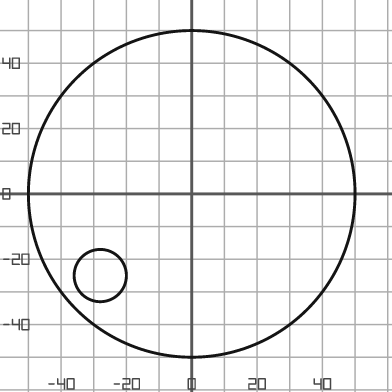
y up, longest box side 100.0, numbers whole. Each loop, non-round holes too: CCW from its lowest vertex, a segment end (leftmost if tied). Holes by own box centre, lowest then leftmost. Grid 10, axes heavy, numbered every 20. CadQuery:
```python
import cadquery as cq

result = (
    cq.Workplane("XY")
    .moveTo(0.0, 0.0)
    .circle(50.0)
    .moveTo(-28.0, -25.0)
    .circle(8.0)
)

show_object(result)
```